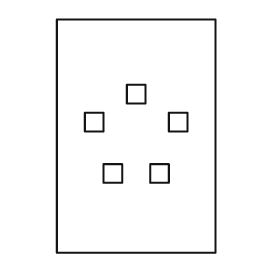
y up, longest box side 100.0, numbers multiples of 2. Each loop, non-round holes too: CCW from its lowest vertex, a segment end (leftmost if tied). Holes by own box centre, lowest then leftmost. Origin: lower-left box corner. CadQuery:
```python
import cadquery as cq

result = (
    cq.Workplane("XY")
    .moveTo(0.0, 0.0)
    .lineTo(68.0, 0.0)
    .lineTo(68.0, 100.0)
    .lineTo(0.0, 100.0)
    .close()
    .moveTo(20.0, 30.0)
    .lineTo(28.0, 30.0)
    .lineTo(28.0, 38.0)
    .lineTo(20.0, 38.0)
    .close()
    .moveTo(40.0, 30.0)
    .lineTo(48.0, 30.0)
    .lineTo(48.0, 38.0)
    .lineTo(40.0, 38.0)
    .close()
    .moveTo(12.0, 52.0)
    .lineTo(20.0, 52.0)
    .lineTo(20.0, 60.0)
    .lineTo(12.0, 60.0)
    .close()
    .moveTo(48.0, 52.0)
    .lineTo(56.0, 52.0)
    .lineTo(56.0, 60.0)
    .lineTo(48.0, 60.0)
    .close()
    .moveTo(30.0, 64.0)
    .lineTo(38.0, 64.0)
    .lineTo(38.0, 72.0)
    .lineTo(30.0, 72.0)
    .close()
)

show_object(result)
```